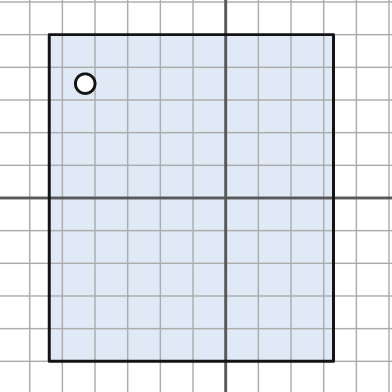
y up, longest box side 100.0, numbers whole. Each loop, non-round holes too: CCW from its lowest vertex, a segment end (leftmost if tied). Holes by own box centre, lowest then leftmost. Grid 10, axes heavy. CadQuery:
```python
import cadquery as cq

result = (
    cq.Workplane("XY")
    .moveTo(-54.0, -50.0)
    .lineTo(33.0, -50.0)
    .lineTo(33.0, 50.0)
    .lineTo(-54.0, 50.0)
    .close()
    .moveTo(-43.0, 35.0)
    .circle(3.0)
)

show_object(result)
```